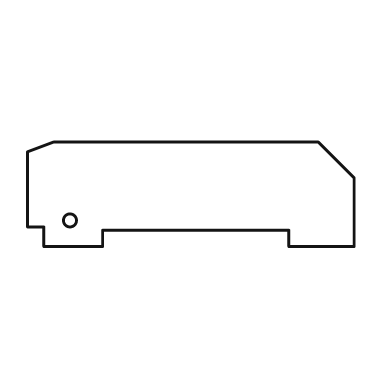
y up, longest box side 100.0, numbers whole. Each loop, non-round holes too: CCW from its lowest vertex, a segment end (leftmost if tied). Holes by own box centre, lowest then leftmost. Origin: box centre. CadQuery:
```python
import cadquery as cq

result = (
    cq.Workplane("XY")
    .moveTo(-45.0, -16.0)
    .lineTo(-27.0, -16.0)
    .lineTo(-27.0, -11.0)
    .lineTo(30.0, -11.0)
    .lineTo(30.0, -16.0)
    .lineTo(50.0, -16.0)
    .lineTo(50.0, 5.0)
    .lineTo(39.0, 16.0)
    .lineTo(-42.0, 16.0)
    .lineTo(-50.0, 13.0)
    .lineTo(-50.0, -10.0)
    .lineTo(-45.0, -10.0)
    .close()
    .moveTo(-37.0, -8.0)
    .circle(2.0)
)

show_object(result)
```